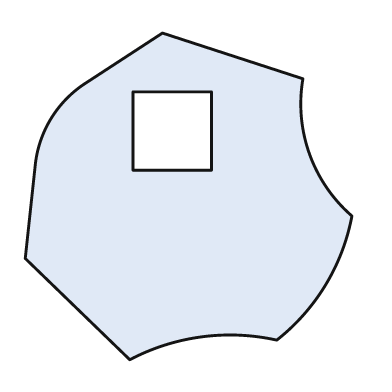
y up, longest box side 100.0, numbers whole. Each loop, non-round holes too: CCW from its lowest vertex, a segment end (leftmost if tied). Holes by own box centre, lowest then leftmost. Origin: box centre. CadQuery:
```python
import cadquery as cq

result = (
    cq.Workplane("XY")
    .moveTo(-18.0, -50.0)
    .threePointArc((4.0, -43.0), (27.0, -44.0))
    .threePointArc((42.0, -27.0), (50.0, -6.0))
    .threePointArc((37.0, 13.0), (35.0, 36.0))
    .lineTo(-8.0, 50.0)
    .lineTo(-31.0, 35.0)
    .threePointArc((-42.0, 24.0), (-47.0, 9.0))
    .lineTo(-50.0, -19.0)
    .close()
    .moveTo(-17.0, 8.0)
    .lineTo(7.0, 8.0)
    .lineTo(7.0, 32.0)
    .lineTo(-17.0, 32.0)
    .close()
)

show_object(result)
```